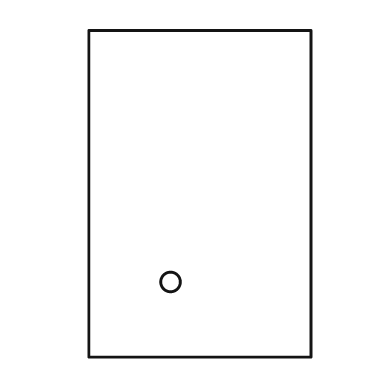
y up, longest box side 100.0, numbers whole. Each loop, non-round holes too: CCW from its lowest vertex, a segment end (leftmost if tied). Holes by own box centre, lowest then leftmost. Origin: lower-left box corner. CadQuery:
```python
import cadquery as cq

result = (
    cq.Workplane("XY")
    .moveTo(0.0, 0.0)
    .lineTo(68.0, 0.0)
    .lineTo(68.0, 100.0)
    .lineTo(0.0, 100.0)
    .close()
    .moveTo(25.0, 23.0)
    .circle(3.0)
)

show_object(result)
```